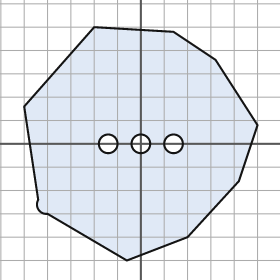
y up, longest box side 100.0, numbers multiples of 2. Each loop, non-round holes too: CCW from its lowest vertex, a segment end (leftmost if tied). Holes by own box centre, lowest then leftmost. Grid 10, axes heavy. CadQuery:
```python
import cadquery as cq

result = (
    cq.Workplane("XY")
    .moveTo(-6.0, -50.0)
    .lineTo(20.0, -40.0)
    .lineTo(42.0, -16.0)
    .lineTo(50.0, 8.0)
    .lineTo(32.0, 36.0)
    .lineTo(14.0, 48.0)
    .lineTo(-20.0, 50.0)
    .lineTo(-50.0, 16.0)
    .lineTo(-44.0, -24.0)
    .threePointArc((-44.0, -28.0), (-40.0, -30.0))
    .close()
    .moveTo(-14.0, 0.0)
    .circle(4.0)
    .moveTo(0.0, 0.0)
    .circle(4.0)
    .moveTo(14.0, 0.0)
    .circle(4.0)
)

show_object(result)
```